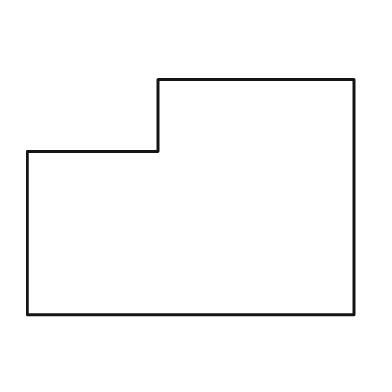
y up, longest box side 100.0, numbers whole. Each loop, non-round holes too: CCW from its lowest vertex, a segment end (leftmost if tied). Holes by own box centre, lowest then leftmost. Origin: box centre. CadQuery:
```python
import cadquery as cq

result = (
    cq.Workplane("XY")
    .moveTo(-50.0, -36.0)
    .lineTo(50.0, -36.0)
    .lineTo(50.0, 36.0)
    .lineTo(-10.0, 36.0)
    .lineTo(-10.0, 14.0)
    .lineTo(-50.0, 14.0)
    .close()
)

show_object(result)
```